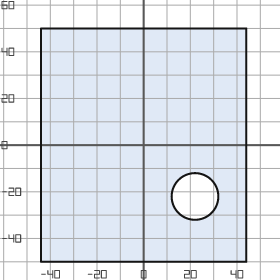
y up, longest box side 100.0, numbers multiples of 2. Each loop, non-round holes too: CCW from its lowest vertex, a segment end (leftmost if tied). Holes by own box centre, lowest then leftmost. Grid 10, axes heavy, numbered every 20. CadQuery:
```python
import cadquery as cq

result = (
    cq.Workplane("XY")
    .moveTo(-44.0, -50.0)
    .lineTo(44.0, -50.0)
    .lineTo(44.0, 50.0)
    .lineTo(-44.0, 50.0)
    .close()
    .moveTo(22.0, -22.0)
    .circle(10.0)
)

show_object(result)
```